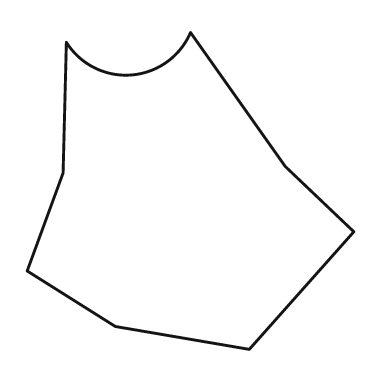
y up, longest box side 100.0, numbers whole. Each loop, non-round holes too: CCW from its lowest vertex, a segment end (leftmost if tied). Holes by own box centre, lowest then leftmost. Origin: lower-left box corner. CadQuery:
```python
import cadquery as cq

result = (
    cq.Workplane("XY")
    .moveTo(68.0, 0.0)
    .lineTo(100.0, 36.0)
    .lineTo(79.0, 56.0)
    .lineTo(50.0, 97.0)
    .threePointArc((32.0, 84.0), (12.0, 94.0))
    .lineTo(11.0, 54.0)
    .lineTo(0.0, 24.0)
    .lineTo(27.0, 7.0)
    .close()
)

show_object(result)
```